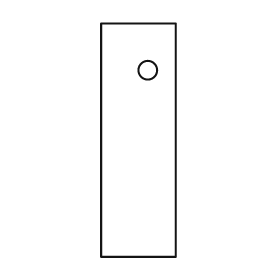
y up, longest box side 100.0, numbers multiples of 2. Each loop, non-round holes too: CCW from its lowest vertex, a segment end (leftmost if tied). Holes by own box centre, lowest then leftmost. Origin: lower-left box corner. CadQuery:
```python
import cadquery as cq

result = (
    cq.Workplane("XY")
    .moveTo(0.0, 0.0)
    .lineTo(32.0, 0.0)
    .lineTo(32.0, 100.0)
    .lineTo(0.0, 100.0)
    .close()
    .moveTo(20.0, 80.0)
    .circle(4.0)
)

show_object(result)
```